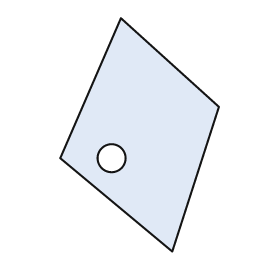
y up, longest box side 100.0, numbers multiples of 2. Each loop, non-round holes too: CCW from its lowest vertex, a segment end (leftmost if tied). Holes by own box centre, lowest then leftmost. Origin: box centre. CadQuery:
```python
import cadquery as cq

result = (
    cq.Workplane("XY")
    .moveTo(14.0, -50.0)
    .lineTo(34.0, 12.0)
    .lineTo(-8.0, 50.0)
    .lineTo(-34.0, -10.0)
    .close()
    .moveTo(-12.0, -10.0)
    .circle(6.0)
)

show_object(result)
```